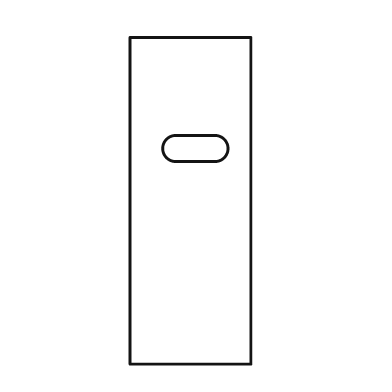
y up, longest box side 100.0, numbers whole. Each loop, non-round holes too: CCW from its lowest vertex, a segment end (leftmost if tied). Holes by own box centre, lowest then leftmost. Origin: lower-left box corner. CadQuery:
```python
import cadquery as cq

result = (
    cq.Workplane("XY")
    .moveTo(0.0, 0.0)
    .lineTo(37.0, 0.0)
    .lineTo(37.0, 100.0)
    .lineTo(0.0, 100.0)
    .close()
    .moveTo(14.0, 62.0)
    .lineTo(26.0, 62.0)
    .threePointArc((30.0, 66.0), (26.0, 70.0))
    .lineTo(14.0, 70.0)
    .threePointArc((10.0, 66.0), (14.0, 62.0))
    .close()
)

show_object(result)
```